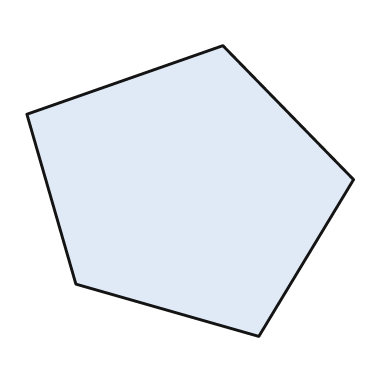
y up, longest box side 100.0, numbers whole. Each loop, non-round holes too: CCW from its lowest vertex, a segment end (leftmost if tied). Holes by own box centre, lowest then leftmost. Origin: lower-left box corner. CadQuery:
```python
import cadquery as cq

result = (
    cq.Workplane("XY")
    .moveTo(71.0, 0.0)
    .lineTo(100.0, 48.0)
    .lineTo(60.0, 89.0)
    .lineTo(0.0, 68.0)
    .lineTo(15.0, 16.0)
    .close()
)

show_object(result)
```